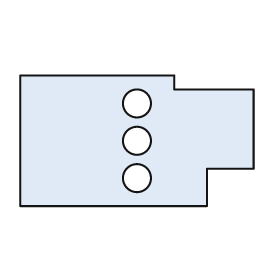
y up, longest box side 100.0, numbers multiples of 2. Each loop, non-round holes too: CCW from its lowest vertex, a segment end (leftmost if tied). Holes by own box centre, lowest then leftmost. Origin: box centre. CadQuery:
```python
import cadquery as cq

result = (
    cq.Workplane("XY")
    .moveTo(-50.0, -28.0)
    .lineTo(30.0, -28.0)
    .lineTo(30.0, -12.0)
    .lineTo(50.0, -12.0)
    .lineTo(50.0, 22.0)
    .lineTo(16.0, 22.0)
    .lineTo(16.0, 28.0)
    .lineTo(-50.0, 28.0)
    .close()
    .moveTo(0.0, -16.0)
    .circle(6.0)
    .moveTo(0.0, 0.0)
    .circle(6.0)
    .moveTo(0.0, 16.0)
    .circle(6.0)
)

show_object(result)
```